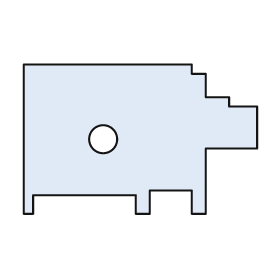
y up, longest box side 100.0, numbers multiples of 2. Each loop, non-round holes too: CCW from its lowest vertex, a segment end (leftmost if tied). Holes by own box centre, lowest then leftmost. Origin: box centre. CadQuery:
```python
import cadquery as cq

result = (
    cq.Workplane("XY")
    .moveTo(-50.0, -32.0)
    .lineTo(-46.0, -32.0)
    .lineTo(-46.0, -24.0)
    .lineTo(-2.0, -24.0)
    .lineTo(-2.0, -32.0)
    .lineTo(4.0, -32.0)
    .lineTo(4.0, -22.0)
    .lineTo(22.0, -22.0)
    .lineTo(22.0, -32.0)
    .lineTo(28.0, -32.0)
    .lineTo(28.0, -4.0)
    .lineTo(50.0, -4.0)
    .lineTo(50.0, 14.0)
    .lineTo(38.0, 14.0)
    .lineTo(38.0, 18.0)
    .lineTo(28.0, 18.0)
    .lineTo(28.0, 28.0)
    .lineTo(22.0, 28.0)
    .lineTo(22.0, 32.0)
    .lineTo(-50.0, 32.0)
    .close()
    .moveTo(-16.0, 0.0)
    .circle(6.0)
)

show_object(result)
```